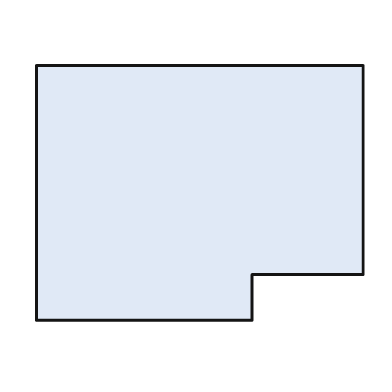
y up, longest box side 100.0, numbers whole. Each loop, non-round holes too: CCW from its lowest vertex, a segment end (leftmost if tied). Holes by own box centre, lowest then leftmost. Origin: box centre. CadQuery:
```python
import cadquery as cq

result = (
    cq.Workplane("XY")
    .moveTo(-50.0, -39.0)
    .lineTo(16.0, -39.0)
    .lineTo(16.0, -25.0)
    .lineTo(50.0, -25.0)
    .lineTo(50.0, 39.0)
    .lineTo(-50.0, 39.0)
    .close()
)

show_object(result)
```